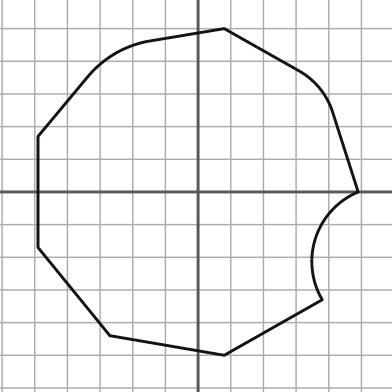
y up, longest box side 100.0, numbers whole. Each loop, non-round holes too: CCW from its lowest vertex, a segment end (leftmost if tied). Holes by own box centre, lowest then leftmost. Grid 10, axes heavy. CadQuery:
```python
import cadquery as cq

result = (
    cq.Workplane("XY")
    .moveTo(8.0, -50.0)
    .lineTo(38.0, -33.0)
    .threePointArc((36.0, -14.0), (49.0, 0.0))
    .lineTo(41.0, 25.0)
    .threePointArc((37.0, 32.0), (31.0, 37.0))
    .lineTo(8.0, 50.0)
    .lineTo(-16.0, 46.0)
    .threePointArc((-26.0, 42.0), (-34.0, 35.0))
    .lineTo(-49.0, 17.0)
    .lineTo(-49.0, -17.0)
    .lineTo(-27.0, -44.0)
    .close()
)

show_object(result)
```